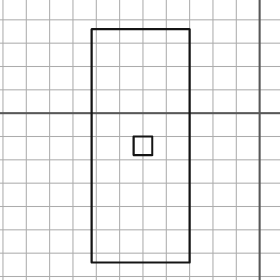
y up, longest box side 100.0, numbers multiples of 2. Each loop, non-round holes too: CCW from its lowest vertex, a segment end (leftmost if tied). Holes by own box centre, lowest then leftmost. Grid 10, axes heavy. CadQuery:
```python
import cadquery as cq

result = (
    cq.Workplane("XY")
    .moveTo(-72.0, -64.0)
    .lineTo(-30.0, -64.0)
    .lineTo(-30.0, 36.0)
    .lineTo(-72.0, 36.0)
    .close()
    .moveTo(-54.0, -18.0)
    .lineTo(-46.0, -18.0)
    .lineTo(-46.0, -10.0)
    .lineTo(-54.0, -10.0)
    .close()
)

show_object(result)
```